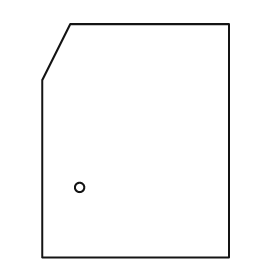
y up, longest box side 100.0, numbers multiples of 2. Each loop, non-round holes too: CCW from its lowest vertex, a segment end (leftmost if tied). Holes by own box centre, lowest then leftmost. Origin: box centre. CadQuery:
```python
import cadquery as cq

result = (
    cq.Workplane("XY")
    .moveTo(-40.0, -50.0)
    .lineTo(40.0, -50.0)
    .lineTo(40.0, 50.0)
    .lineTo(-28.0, 50.0)
    .lineTo(-40.0, 26.0)
    .close()
    .moveTo(-24.0, -20.0)
    .circle(2.0)
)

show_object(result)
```